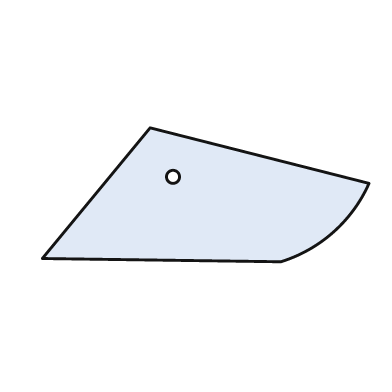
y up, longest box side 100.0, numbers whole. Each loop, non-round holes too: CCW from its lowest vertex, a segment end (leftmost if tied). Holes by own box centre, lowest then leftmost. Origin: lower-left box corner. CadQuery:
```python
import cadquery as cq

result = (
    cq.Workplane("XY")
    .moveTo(73.0, 0.0)
    .threePointArc((89.0, 9.0), (100.0, 24.0))
    .lineTo(33.0, 41.0)
    .lineTo(0.0, 1.0)
    .close()
    .moveTo(40.0, 26.0)
    .circle(2.0)
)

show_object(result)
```